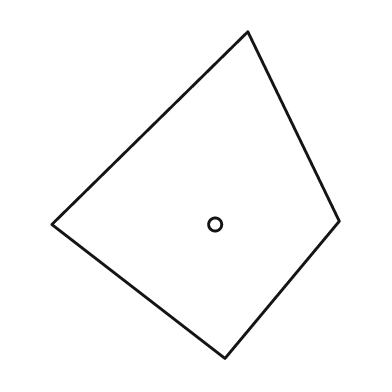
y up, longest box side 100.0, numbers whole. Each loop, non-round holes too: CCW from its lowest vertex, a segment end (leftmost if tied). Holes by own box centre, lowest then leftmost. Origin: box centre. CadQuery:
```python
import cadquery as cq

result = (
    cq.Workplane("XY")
    .moveTo(9.0, -50.0)
    .lineTo(44.0, -8.0)
    .lineTo(16.0, 50.0)
    .lineTo(-44.0, -9.0)
    .close()
    .moveTo(6.0, -9.0)
    .circle(2.0)
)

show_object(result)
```